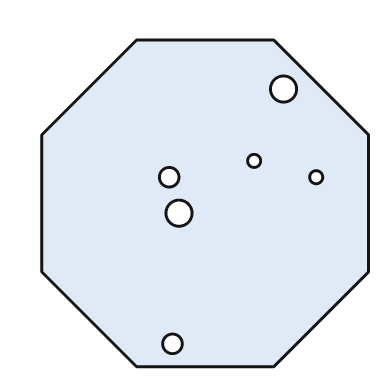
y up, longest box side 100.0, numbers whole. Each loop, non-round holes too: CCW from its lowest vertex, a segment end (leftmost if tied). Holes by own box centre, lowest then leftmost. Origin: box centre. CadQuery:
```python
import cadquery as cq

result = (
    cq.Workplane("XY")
    .moveTo(-21.0, -50.0)
    .lineTo(21.0, -50.0)
    .lineTo(50.0, -21.0)
    .lineTo(50.0, 21.0)
    .lineTo(21.0, 50.0)
    .lineTo(-21.0, 50.0)
    .lineTo(-50.0, 21.0)
    .lineTo(-50.0, -21.0)
    .close()
    .moveTo(-10.0, -43.0)
    .circle(3.0)
    .moveTo(-8.0, -3.0)
    .circle(4.0)
    .moveTo(-11.0, 8.0)
    .circle(3.0)
    .moveTo(34.0, 8.0)
    .circle(2.0)
    .moveTo(15.0, 13.0)
    .circle(2.0)
    .moveTo(24.0, 35.0)
    .circle(4.0)
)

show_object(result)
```